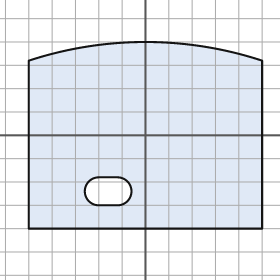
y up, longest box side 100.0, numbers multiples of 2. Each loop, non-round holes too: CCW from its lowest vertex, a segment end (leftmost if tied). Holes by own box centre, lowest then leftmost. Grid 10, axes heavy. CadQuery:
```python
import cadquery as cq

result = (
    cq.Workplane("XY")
    .moveTo(-50.0, -40.0)
    .lineTo(50.0, -40.0)
    .lineTo(50.0, 32.0)
    .threePointArc((0.0, 40.0), (-50.0, 32.0))
    .close()
    .moveTo(-20.0, -30.0)
    .lineTo(-12.0, -30.0)
    .threePointArc((-6.0, -24.0), (-12.0, -18.0))
    .lineTo(-20.0, -18.0)
    .threePointArc((-26.0, -24.0), (-20.0, -30.0))
    .close()
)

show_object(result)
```